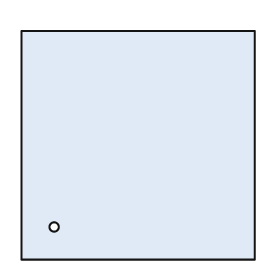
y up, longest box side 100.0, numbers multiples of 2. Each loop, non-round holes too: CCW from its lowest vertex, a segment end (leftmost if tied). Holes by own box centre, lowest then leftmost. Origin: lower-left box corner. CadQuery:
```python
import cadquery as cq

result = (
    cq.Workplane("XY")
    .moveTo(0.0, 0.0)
    .lineTo(100.0, 0.0)
    .lineTo(100.0, 98.0)
    .lineTo(0.0, 98.0)
    .close()
    .moveTo(14.0, 14.0)
    .circle(2.0)
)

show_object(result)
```